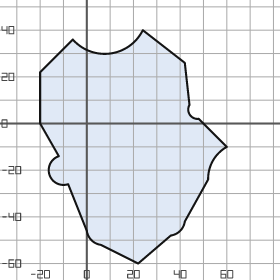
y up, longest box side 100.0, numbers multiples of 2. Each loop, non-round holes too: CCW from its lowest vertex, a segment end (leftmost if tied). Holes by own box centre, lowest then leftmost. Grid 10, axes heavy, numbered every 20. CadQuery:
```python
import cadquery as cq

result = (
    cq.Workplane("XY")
    .moveTo(22.0, -60.0)
    .lineTo(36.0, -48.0)
    .threePointArc((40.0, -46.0), (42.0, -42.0))
    .lineTo(52.0, -24.0)
    .threePointArc((54.0, -16.0), (60.0, -10.0))
    .lineTo(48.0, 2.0)
    .threePointArc((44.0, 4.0), (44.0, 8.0))
    .lineTo(42.0, 26.0)
    .lineTo(24.0, 40.0)
    .threePointArc((10.0, 30.0), (-6.0, 36.0))
    .lineTo(-20.0, 22.0)
    .lineTo(-20.0, 0.0)
    .lineTo(-12.0, -14.0)
    .threePointArc((-16.0, -22.0), (-8.0, -26.0))
    .lineTo(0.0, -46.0)
    .threePointArc((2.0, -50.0), (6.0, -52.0))
    .close()
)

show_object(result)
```